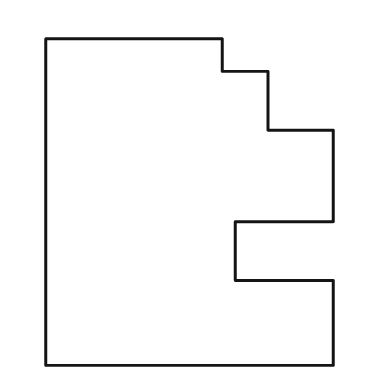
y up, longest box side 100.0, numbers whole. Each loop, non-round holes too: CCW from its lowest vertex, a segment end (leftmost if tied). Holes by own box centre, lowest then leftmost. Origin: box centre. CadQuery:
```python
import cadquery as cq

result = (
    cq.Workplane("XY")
    .moveTo(-44.0, -50.0)
    .lineTo(44.0, -50.0)
    .lineTo(44.0, -24.0)
    .lineTo(14.0, -24.0)
    .lineTo(14.0, -6.0)
    .lineTo(44.0, -6.0)
    .lineTo(44.0, 22.0)
    .lineTo(24.0, 22.0)
    .lineTo(24.0, 40.0)
    .lineTo(10.0, 40.0)
    .lineTo(10.0, 50.0)
    .lineTo(-44.0, 50.0)
    .close()
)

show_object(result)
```